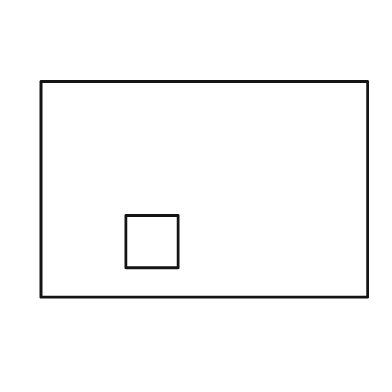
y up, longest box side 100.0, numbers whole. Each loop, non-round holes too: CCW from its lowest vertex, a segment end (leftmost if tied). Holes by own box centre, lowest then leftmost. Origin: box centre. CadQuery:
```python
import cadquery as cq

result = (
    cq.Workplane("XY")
    .moveTo(-50.0, -33.0)
    .lineTo(50.0, -33.0)
    .lineTo(50.0, 33.0)
    .lineTo(-50.0, 33.0)
    .close()
    .moveTo(-24.0, -24.0)
    .lineTo(-8.0, -24.0)
    .lineTo(-8.0, -8.0)
    .lineTo(-24.0, -8.0)
    .close()
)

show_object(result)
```